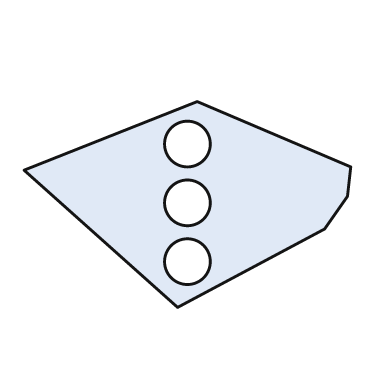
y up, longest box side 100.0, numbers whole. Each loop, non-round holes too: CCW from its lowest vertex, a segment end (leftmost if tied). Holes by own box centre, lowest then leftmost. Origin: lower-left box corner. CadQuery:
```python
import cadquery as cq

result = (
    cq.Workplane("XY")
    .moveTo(47.0, 0.0)
    .lineTo(92.0, 24.0)
    .lineTo(99.0, 34.0)
    .lineTo(100.0, 43.0)
    .lineTo(53.0, 63.0)
    .lineTo(0.0, 42.0)
    .close()
    .moveTo(50.0, 14.0)
    .circle(7.0)
    .moveTo(50.0, 32.0)
    .circle(7.0)
    .moveTo(50.0, 50.0)
    .circle(7.0)
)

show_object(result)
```